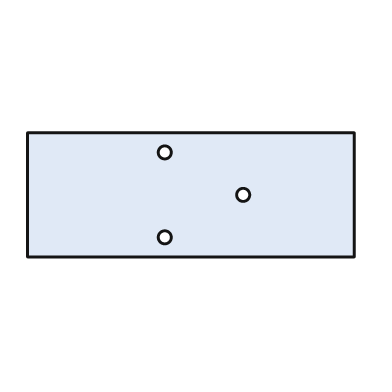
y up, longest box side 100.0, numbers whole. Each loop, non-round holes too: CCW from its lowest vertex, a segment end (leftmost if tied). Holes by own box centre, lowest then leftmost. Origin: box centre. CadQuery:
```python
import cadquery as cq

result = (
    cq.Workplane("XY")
    .moveTo(-50.0, -19.0)
    .lineTo(50.0, -19.0)
    .lineTo(50.0, 19.0)
    .lineTo(-50.0, 19.0)
    .close()
    .moveTo(-8.0, -13.0)
    .circle(2.0)
    .moveTo(16.0, 0.0)
    .circle(2.0)
    .moveTo(-8.0, 13.0)
    .circle(2.0)
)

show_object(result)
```